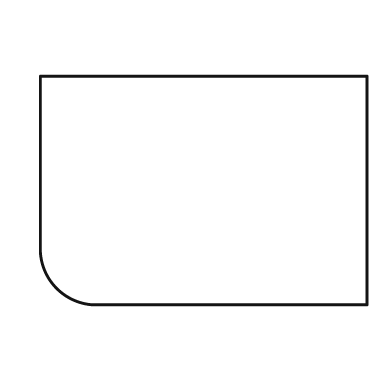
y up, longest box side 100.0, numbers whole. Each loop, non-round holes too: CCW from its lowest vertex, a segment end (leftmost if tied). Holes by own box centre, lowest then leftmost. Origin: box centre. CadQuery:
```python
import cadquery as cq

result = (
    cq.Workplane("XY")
    .moveTo(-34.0, -35.0)
    .lineTo(50.0, -35.0)
    .lineTo(50.0, 35.0)
    .lineTo(-50.0, 35.0)
    .lineTo(-50.0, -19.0)
    .threePointArc((-45.0, -30.0), (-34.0, -35.0))
    .close()
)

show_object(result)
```